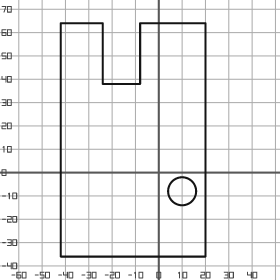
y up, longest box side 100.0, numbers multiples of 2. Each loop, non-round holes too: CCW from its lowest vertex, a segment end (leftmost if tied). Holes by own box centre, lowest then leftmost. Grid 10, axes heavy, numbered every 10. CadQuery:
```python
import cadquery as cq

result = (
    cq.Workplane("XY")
    .moveTo(-42.0, -36.0)
    .lineTo(20.0, -36.0)
    .lineTo(20.0, 64.0)
    .lineTo(-8.0, 64.0)
    .lineTo(-8.0, 38.0)
    .lineTo(-24.0, 38.0)
    .lineTo(-24.0, 64.0)
    .lineTo(-42.0, 64.0)
    .close()
    .moveTo(10.0, -8.0)
    .circle(6.0)
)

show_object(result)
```